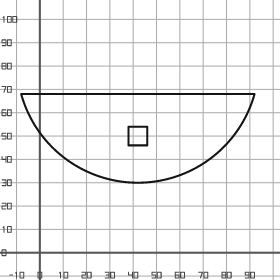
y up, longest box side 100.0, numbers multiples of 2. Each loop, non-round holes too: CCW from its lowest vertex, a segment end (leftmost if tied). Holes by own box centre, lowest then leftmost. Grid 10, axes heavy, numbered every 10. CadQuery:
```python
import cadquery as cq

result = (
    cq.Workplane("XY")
    .moveTo(-8.0, 68.0)
    .threePointArc((42.0, 30.0), (92.0, 68.0))
    .close()
    .moveTo(38.0, 46.0)
    .lineTo(46.0, 46.0)
    .lineTo(46.0, 54.0)
    .lineTo(38.0, 54.0)
    .close()
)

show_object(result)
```